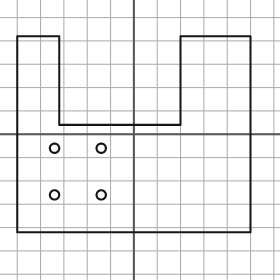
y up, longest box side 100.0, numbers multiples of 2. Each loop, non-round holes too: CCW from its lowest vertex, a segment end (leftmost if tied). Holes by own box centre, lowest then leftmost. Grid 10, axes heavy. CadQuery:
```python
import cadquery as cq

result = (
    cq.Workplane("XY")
    .moveTo(-50.0, -42.0)
    .lineTo(50.0, -42.0)
    .lineTo(50.0, 42.0)
    .lineTo(20.0, 42.0)
    .lineTo(20.0, 4.0)
    .lineTo(-32.0, 4.0)
    .lineTo(-32.0, 42.0)
    .lineTo(-50.0, 42.0)
    .close()
    .moveTo(-34.0, -26.0)
    .circle(2.0)
    .moveTo(-14.0, -26.0)
    .circle(2.0)
    .moveTo(-34.0, -6.0)
    .circle(2.0)
    .moveTo(-14.0, -6.0)
    .circle(2.0)
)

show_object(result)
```